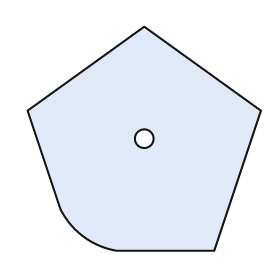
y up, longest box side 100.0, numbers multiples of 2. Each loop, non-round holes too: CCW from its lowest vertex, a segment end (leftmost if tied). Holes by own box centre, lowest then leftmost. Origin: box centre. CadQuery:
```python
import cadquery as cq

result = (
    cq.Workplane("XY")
    .moveTo(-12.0, -48.0)
    .lineTo(30.0, -48.0)
    .lineTo(50.0, 12.0)
    .lineTo(0.0, 48.0)
    .lineTo(-50.0, 12.0)
    .lineTo(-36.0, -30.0)
    .threePointArc((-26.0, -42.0), (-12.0, -48.0))
    .close()
    .moveTo(0.0, 0.0)
    .circle(4.0)
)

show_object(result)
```